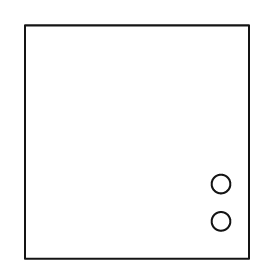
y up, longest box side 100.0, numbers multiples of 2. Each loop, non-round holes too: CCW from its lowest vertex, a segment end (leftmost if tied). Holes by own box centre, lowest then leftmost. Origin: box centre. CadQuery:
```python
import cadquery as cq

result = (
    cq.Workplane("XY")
    .moveTo(-48.0, -50.0)
    .lineTo(48.0, -50.0)
    .lineTo(48.0, 50.0)
    .lineTo(-48.0, 50.0)
    .close()
    .moveTo(36.0, -34.0)
    .circle(4.0)
    .moveTo(36.0, -18.0)
    .circle(4.0)
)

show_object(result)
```